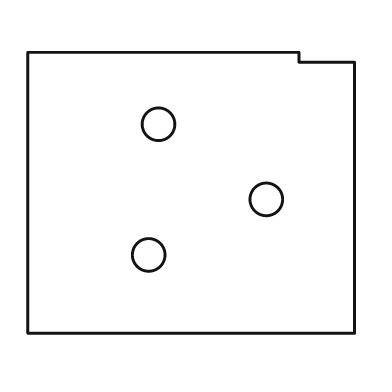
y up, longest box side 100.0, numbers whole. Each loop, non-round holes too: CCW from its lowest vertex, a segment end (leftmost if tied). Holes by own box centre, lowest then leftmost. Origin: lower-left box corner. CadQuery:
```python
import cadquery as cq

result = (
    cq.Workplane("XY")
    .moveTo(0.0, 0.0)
    .lineTo(100.0, 0.0)
    .lineTo(100.0, 83.0)
    .lineTo(83.0, 83.0)
    .lineTo(83.0, 86.0)
    .lineTo(0.0, 86.0)
    .close()
    .moveTo(37.0, 24.0)
    .circle(5.0)
    .moveTo(73.0, 41.0)
    .circle(5.0)
    .moveTo(40.0, 64.0)
    .circle(5.0)
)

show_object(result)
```